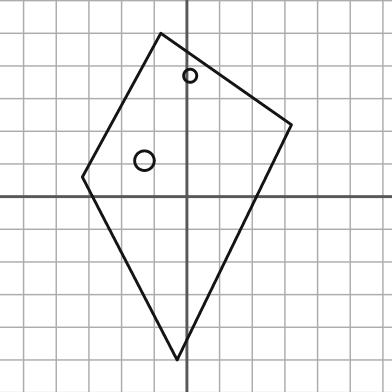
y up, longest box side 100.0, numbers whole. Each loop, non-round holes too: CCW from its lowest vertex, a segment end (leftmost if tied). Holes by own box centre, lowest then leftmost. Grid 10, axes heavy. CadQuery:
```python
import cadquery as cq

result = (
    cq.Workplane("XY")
    .moveTo(-3.0, -50.0)
    .lineTo(32.0, 22.0)
    .lineTo(-8.0, 50.0)
    .lineTo(-32.0, 6.0)
    .close()
    .moveTo(-13.0, 11.0)
    .circle(3.0)
    .moveTo(1.0, 37.0)
    .circle(2.0)
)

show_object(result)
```